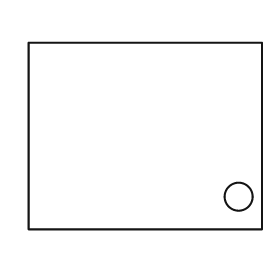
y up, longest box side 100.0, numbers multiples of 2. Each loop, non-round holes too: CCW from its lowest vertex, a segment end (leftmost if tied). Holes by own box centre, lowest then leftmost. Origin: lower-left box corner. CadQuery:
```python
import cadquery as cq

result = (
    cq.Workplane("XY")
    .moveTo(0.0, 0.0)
    .lineTo(100.0, 0.0)
    .lineTo(100.0, 80.0)
    .lineTo(0.0, 80.0)
    .close()
    .moveTo(90.0, 14.0)
    .circle(6.0)
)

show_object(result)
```